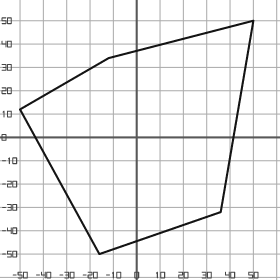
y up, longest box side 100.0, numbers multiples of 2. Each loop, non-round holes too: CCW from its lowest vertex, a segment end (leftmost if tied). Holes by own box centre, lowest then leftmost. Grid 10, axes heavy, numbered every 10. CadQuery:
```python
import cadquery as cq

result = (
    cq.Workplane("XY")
    .moveTo(-16.0, -50.0)
    .lineTo(36.0, -32.0)
    .lineTo(50.0, 50.0)
    .lineTo(-12.0, 34.0)
    .lineTo(-50.0, 12.0)
    .close()
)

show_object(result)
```